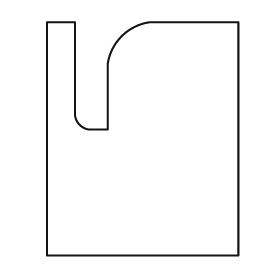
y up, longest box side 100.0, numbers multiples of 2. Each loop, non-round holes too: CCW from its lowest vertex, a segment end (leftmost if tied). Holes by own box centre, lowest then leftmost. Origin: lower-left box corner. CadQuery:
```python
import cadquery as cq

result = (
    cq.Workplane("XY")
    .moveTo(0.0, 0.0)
    .lineTo(82.0, 0.0)
    .lineTo(82.0, 100.0)
    .lineTo(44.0, 100.0)
    .threePointArc((32.0, 94.0), (26.0, 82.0))
    .lineTo(26.0, 54.0)
    .lineTo(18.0, 54.0)
    .threePointArc((14.0, 56.0), (12.0, 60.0))
    .lineTo(12.0, 100.0)
    .lineTo(0.0, 100.0)
    .close()
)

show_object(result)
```